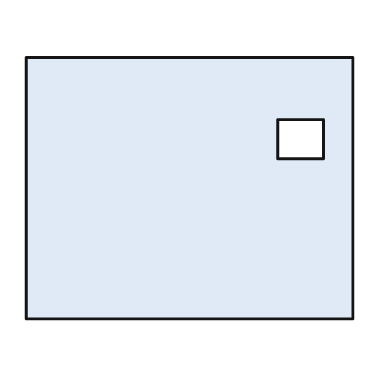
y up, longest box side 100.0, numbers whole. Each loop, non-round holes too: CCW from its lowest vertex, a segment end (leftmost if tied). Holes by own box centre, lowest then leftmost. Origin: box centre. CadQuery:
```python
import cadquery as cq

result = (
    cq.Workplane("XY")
    .moveTo(-50.0, -40.0)
    .lineTo(50.0, -40.0)
    .lineTo(50.0, 40.0)
    .lineTo(-50.0, 40.0)
    .close()
    .moveTo(27.0, 9.0)
    .lineTo(41.0, 9.0)
    .lineTo(41.0, 21.0)
    .lineTo(27.0, 21.0)
    .close()
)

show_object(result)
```